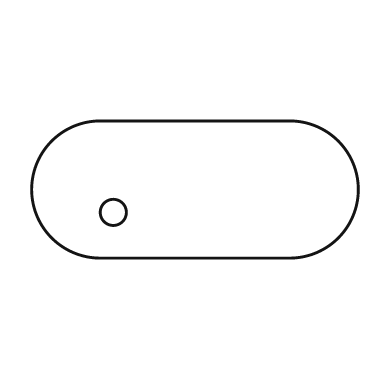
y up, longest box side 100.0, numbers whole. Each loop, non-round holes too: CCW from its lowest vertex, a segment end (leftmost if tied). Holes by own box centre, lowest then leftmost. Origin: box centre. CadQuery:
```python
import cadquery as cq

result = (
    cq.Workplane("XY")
    .moveTo(-29.0, -21.0)
    .lineTo(29.0, -21.0)
    .threePointArc((50.0, 0.0), (29.0, 21.0))
    .lineTo(-29.0, 21.0)
    .threePointArc((-50.0, 0.0), (-29.0, -21.0))
    .close()
    .moveTo(-25.0, -7.0)
    .circle(4.0)
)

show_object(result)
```